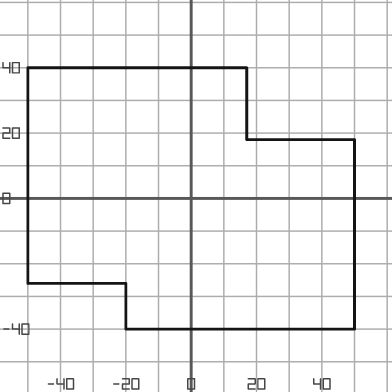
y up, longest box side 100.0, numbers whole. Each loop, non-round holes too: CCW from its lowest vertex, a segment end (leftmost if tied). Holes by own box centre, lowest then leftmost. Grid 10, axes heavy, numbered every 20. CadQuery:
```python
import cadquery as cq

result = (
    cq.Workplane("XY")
    .moveTo(-20.0, -40.0)
    .lineTo(50.0, -40.0)
    .lineTo(50.0, 18.0)
    .lineTo(17.0, 18.0)
    .lineTo(17.0, 40.0)
    .lineTo(-50.0, 40.0)
    .lineTo(-50.0, -26.0)
    .lineTo(-20.0, -26.0)
    .close()
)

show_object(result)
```